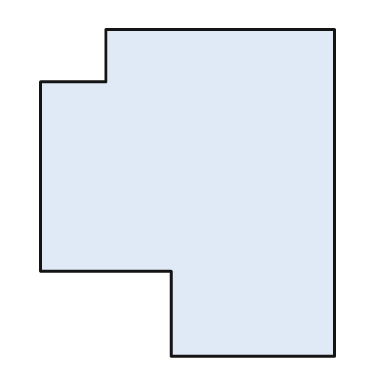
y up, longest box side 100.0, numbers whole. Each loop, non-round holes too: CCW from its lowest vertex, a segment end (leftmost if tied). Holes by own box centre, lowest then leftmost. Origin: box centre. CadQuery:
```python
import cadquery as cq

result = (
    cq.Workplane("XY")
    .moveTo(-5.0, -50.0)
    .lineTo(45.0, -50.0)
    .lineTo(45.0, 50.0)
    .lineTo(-25.0, 50.0)
    .lineTo(-25.0, 34.0)
    .lineTo(-45.0, 34.0)
    .lineTo(-45.0, -24.0)
    .lineTo(-5.0, -24.0)
    .close()
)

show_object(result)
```